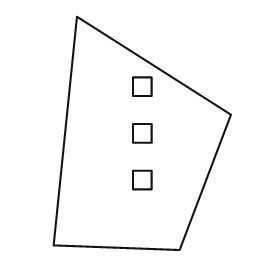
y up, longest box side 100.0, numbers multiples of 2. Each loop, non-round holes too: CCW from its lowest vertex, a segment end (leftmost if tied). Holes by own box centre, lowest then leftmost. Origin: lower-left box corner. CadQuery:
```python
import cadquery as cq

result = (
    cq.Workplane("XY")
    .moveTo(54.0, 0.0)
    .lineTo(76.0, 58.0)
    .lineTo(10.0, 100.0)
    .lineTo(0.0, 2.0)
    .close()
    .moveTo(34.0, 26.0)
    .lineTo(42.0, 26.0)
    .lineTo(42.0, 34.0)
    .lineTo(34.0, 34.0)
    .close()
    .moveTo(34.0, 46.0)
    .lineTo(42.0, 46.0)
    .lineTo(42.0, 54.0)
    .lineTo(34.0, 54.0)
    .close()
    .moveTo(34.0, 66.0)
    .lineTo(42.0, 66.0)
    .lineTo(42.0, 74.0)
    .lineTo(34.0, 74.0)
    .close()
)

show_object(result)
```